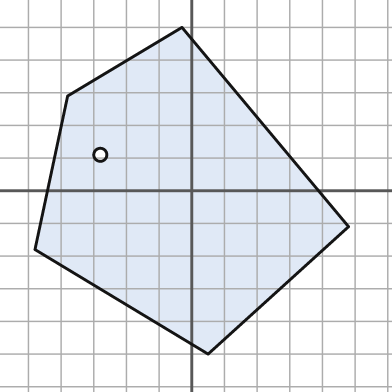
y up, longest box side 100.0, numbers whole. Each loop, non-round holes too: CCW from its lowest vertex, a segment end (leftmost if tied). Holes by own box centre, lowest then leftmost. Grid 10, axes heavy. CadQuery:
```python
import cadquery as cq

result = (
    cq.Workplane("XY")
    .moveTo(5.0, -50.0)
    .lineTo(48.0, -11.0)
    .lineTo(-3.0, 50.0)
    .lineTo(-38.0, 29.0)
    .lineTo(-48.0, -18.0)
    .close()
    .moveTo(-28.0, 11.0)
    .circle(2.0)
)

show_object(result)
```